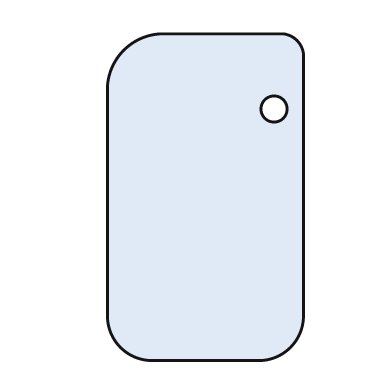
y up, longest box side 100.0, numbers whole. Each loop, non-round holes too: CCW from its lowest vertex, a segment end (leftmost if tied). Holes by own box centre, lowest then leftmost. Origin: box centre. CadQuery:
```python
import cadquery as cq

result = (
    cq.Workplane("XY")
    .moveTo(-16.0, -50.0)
    .lineTo(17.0, -50.0)
    .threePointArc((26.0, -46.0), (30.0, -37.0))
    .lineTo(30.0, 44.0)
    .threePointArc((28.0, 48.0), (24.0, 50.0))
    .lineTo(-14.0, 50.0)
    .threePointArc((-25.0, 45.0), (-30.0, 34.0))
    .lineTo(-30.0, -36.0)
    .threePointArc((-26.0, -46.0), (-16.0, -50.0))
    .close()
    .moveTo(21.0, 27.0)
    .circle(4.0)
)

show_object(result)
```